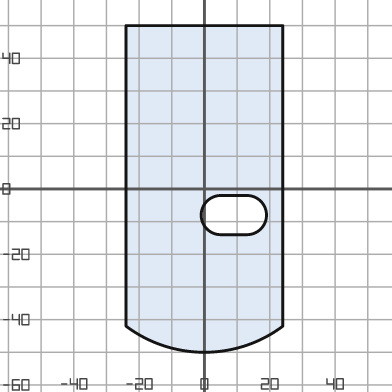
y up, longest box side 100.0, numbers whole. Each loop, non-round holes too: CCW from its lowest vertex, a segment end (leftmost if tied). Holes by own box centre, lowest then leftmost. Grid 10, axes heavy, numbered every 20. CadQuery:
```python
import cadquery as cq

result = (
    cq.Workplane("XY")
    .moveTo(-24.0, -42.0)
    .threePointArc((0.0, -50.0), (24.0, -42.0))
    .lineTo(24.0, 50.0)
    .lineTo(-24.0, 50.0)
    .close()
    .moveTo(5.0, -14.0)
    .lineTo(13.0, -14.0)
    .threePointArc((19.0, -8.0), (13.0, -2.0))
    .lineTo(5.0, -2.0)
    .threePointArc((-1.0, -8.0), (5.0, -14.0))
    .close()
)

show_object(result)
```